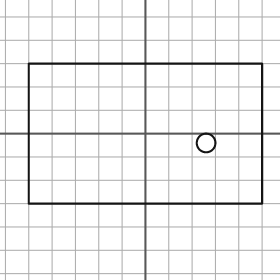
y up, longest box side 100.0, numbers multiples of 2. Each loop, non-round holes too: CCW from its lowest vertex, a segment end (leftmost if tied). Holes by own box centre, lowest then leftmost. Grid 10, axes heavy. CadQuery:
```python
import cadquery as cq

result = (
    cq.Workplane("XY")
    .moveTo(-50.0, -30.0)
    .lineTo(50.0, -30.0)
    .lineTo(50.0, 30.0)
    .lineTo(-50.0, 30.0)
    .close()
    .moveTo(26.0, -4.0)
    .circle(4.0)
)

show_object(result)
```